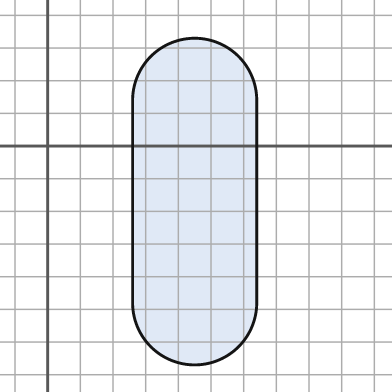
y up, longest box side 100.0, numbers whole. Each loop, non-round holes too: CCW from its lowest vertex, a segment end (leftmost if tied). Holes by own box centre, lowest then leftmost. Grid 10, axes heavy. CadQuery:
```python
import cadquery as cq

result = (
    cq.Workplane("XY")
    .moveTo(26.0, -48.0)
    .threePointArc((45.0, -67.0), (64.0, -48.0))
    .lineTo(64.0, 14.0)
    .threePointArc((45.0, 33.0), (26.0, 14.0))
    .close()
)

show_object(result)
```